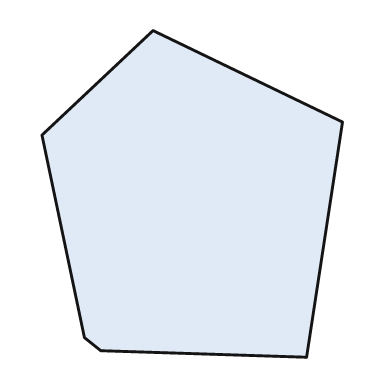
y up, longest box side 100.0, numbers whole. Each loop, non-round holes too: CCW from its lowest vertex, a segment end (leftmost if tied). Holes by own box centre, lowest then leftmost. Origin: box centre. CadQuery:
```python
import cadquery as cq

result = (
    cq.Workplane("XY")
    .moveTo(35.0, -50.0)
    .lineTo(46.0, 22.0)
    .lineTo(-12.0, 50.0)
    .lineTo(-46.0, 18.0)
    .lineTo(-33.0, -44.0)
    .lineTo(-28.0, -48.0)
    .close()
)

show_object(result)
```